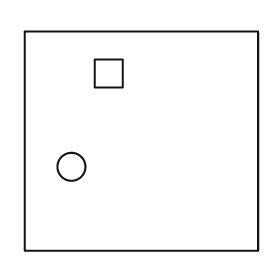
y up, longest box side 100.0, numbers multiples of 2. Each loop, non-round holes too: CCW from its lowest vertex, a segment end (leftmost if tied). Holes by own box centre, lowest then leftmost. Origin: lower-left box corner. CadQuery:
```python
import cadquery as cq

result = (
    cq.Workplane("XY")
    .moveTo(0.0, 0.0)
    .lineTo(100.0, 0.0)
    .lineTo(100.0, 94.0)
    .lineTo(0.0, 94.0)
    .close()
    .moveTo(20.0, 36.0)
    .circle(6.0)
    .moveTo(30.0, 70.0)
    .lineTo(42.0, 70.0)
    .lineTo(42.0, 82.0)
    .lineTo(30.0, 82.0)
    .close()
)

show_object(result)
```